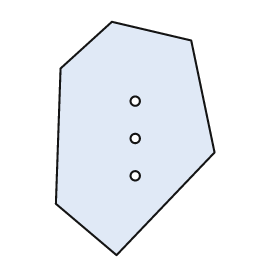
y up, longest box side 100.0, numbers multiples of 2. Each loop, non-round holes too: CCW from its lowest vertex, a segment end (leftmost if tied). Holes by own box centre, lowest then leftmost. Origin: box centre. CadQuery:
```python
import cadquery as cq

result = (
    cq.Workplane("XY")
    .moveTo(-8.0, -50.0)
    .lineTo(34.0, -6.0)
    .lineTo(24.0, 42.0)
    .lineTo(-10.0, 50.0)
    .lineTo(-32.0, 30.0)
    .lineTo(-34.0, -28.0)
    .close()
    .moveTo(0.0, -16.0)
    .circle(2.0)
    .moveTo(0.0, 0.0)
    .circle(2.0)
    .moveTo(0.0, 16.0)
    .circle(2.0)
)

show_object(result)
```